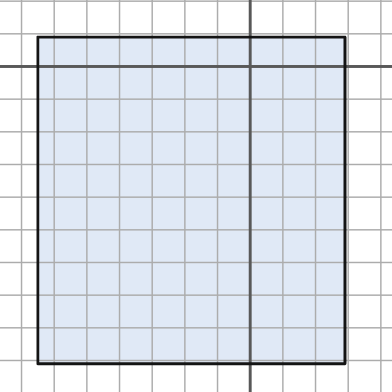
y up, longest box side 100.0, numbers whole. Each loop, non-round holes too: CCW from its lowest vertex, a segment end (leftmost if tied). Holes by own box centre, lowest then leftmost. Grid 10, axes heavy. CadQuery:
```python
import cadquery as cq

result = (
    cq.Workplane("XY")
    .moveTo(-65.0, -91.0)
    .lineTo(29.0, -91.0)
    .lineTo(29.0, 9.0)
    .lineTo(-65.0, 9.0)
    .close()
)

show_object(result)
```